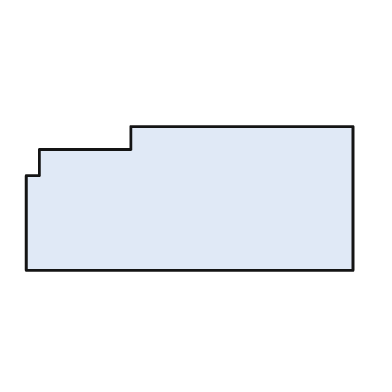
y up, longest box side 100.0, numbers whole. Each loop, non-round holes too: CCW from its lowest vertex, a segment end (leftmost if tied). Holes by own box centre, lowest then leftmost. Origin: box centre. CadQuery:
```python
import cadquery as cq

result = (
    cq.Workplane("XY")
    .moveTo(-50.0, -22.0)
    .lineTo(50.0, -22.0)
    .lineTo(50.0, 22.0)
    .lineTo(-18.0, 22.0)
    .lineTo(-18.0, 15.0)
    .lineTo(-46.0, 15.0)
    .lineTo(-46.0, 7.0)
    .lineTo(-50.0, 7.0)
    .close()
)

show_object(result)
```